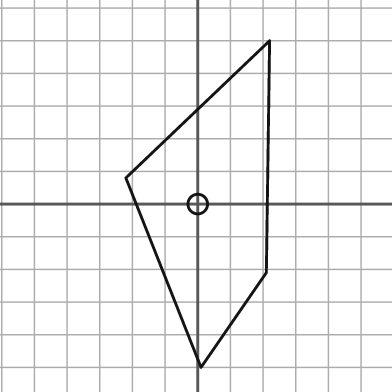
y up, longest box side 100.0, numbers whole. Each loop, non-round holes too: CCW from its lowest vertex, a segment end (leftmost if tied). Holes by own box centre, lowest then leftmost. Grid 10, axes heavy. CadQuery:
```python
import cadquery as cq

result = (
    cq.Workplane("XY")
    .moveTo(1.0, -50.0)
    .lineTo(21.0, -21.0)
    .lineTo(22.0, 50.0)
    .lineTo(-22.0, 8.0)
    .close()
    .moveTo(0.0, 0.0)
    .circle(3.0)
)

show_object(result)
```